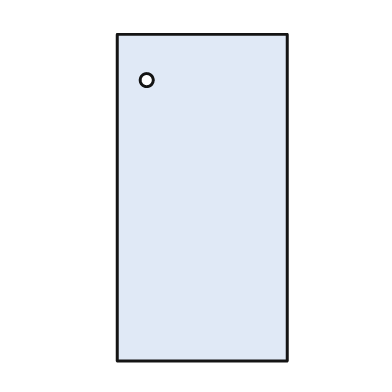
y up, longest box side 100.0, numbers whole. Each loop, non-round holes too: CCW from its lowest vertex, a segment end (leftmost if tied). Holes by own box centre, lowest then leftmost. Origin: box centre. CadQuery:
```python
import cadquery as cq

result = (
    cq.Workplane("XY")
    .moveTo(-26.0, -50.0)
    .lineTo(26.0, -50.0)
    .lineTo(26.0, 50.0)
    .lineTo(-26.0, 50.0)
    .close()
    .moveTo(-17.0, 36.0)
    .circle(2.0)
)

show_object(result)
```